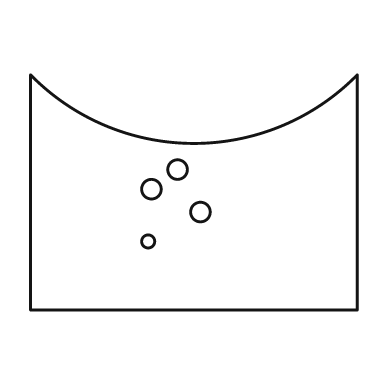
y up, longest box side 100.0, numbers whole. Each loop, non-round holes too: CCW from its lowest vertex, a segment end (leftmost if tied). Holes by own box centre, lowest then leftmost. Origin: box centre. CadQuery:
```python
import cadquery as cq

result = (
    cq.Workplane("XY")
    .moveTo(-50.0, -36.0)
    .lineTo(50.0, -36.0)
    .lineTo(50.0, 36.0)
    .threePointArc((0.0, 15.0), (-50.0, 36.0))
    .close()
    .moveTo(-14.0, -15.0)
    .circle(2.0)
    .moveTo(2.0, -6.0)
    .circle(3.0)
    .moveTo(-13.0, 1.0)
    .circle(3.0)
    .moveTo(-5.0, 7.0)
    .circle(3.0)
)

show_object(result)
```